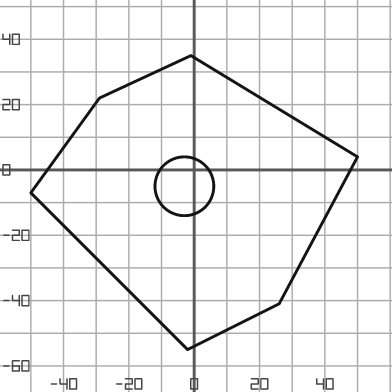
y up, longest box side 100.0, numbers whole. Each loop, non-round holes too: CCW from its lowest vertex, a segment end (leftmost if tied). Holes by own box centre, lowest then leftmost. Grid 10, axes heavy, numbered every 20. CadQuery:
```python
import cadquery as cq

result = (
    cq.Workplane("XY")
    .moveTo(-2.0, -55.0)
    .lineTo(26.0, -41.0)
    .lineTo(50.0, 4.0)
    .lineTo(-1.0, 35.0)
    .lineTo(-29.0, 22.0)
    .lineTo(-50.0, -7.0)
    .close()
    .moveTo(-3.0, -5.0)
    .circle(9.0)
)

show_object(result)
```